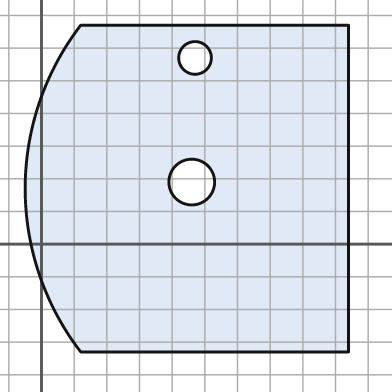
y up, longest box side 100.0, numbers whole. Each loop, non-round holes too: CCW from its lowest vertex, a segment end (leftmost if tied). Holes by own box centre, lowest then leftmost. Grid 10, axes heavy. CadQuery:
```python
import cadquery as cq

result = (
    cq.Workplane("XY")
    .moveTo(12.0, -33.0)
    .lineTo(94.0, -33.0)
    .lineTo(94.0, 67.0)
    .lineTo(12.0, 67.0)
    .threePointArc((-5.0, 17.0), (12.0, -33.0))
    .close()
    .moveTo(46.0, 19.0)
    .circle(7.0)
    .moveTo(47.0, 57.0)
    .circle(5.0)
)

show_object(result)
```